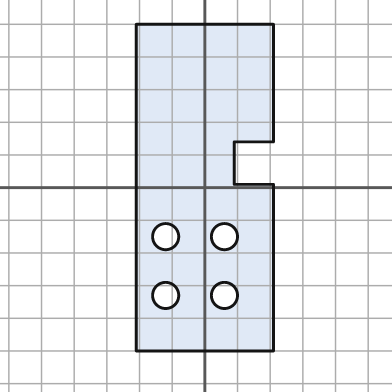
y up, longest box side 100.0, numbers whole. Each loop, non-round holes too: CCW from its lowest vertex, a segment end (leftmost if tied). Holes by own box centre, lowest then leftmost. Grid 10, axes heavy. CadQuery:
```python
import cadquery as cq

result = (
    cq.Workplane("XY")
    .moveTo(-21.0, -50.0)
    .lineTo(21.0, -50.0)
    .lineTo(21.0, 1.0)
    .lineTo(9.0, 1.0)
    .lineTo(9.0, 14.0)
    .lineTo(21.0, 14.0)
    .lineTo(21.0, 50.0)
    .lineTo(-21.0, 50.0)
    .close()
    .moveTo(-12.0, -33.0)
    .circle(4.0)
    .moveTo(6.0, -33.0)
    .circle(4.0)
    .moveTo(-12.0, -15.0)
    .circle(4.0)
    .moveTo(6.0, -15.0)
    .circle(4.0)
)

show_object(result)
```